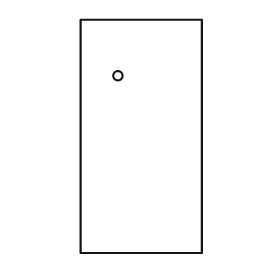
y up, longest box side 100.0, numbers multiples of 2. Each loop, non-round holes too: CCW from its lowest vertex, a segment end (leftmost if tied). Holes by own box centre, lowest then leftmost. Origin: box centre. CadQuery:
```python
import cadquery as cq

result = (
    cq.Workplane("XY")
    .moveTo(-26.0, -50.0)
    .lineTo(26.0, -50.0)
    .lineTo(26.0, 50.0)
    .lineTo(-26.0, 50.0)
    .close()
    .moveTo(-10.0, 26.0)
    .circle(2.0)
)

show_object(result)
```